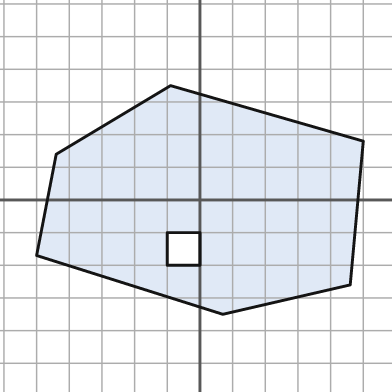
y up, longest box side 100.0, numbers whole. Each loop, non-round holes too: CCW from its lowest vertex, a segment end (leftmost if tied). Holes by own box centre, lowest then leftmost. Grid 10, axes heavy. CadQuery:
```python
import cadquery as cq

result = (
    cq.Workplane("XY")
    .moveTo(7.0, -35.0)
    .lineTo(46.0, -26.0)
    .lineTo(50.0, 18.0)
    .lineTo(-9.0, 35.0)
    .lineTo(-44.0, 14.0)
    .lineTo(-50.0, -17.0)
    .close()
    .moveTo(-10.0, -20.0)
    .lineTo(0.0, -20.0)
    .lineTo(0.0, -10.0)
    .lineTo(-10.0, -10.0)
    .close()
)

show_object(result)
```